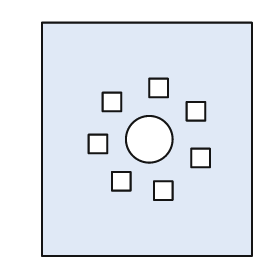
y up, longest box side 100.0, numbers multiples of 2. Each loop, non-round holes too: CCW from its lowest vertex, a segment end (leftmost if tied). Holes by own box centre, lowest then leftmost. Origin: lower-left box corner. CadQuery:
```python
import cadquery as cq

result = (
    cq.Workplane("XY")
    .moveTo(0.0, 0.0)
    .lineTo(90.0, 0.0)
    .lineTo(90.0, 100.0)
    .lineTo(0.0, 100.0)
    .close()
    .moveTo(48.0, 24.0)
    .lineTo(56.0, 24.0)
    .lineTo(56.0, 32.0)
    .lineTo(48.0, 32.0)
    .close()
    .moveTo(30.0, 28.0)
    .lineTo(38.0, 28.0)
    .lineTo(38.0, 36.0)
    .lineTo(30.0, 36.0)
    .close()
    .moveTo(64.0, 38.0)
    .lineTo(72.0, 38.0)
    .lineTo(72.0, 46.0)
    .lineTo(64.0, 46.0)
    .close()
    .moveTo(20.0, 44.0)
    .lineTo(28.0, 44.0)
    .lineTo(28.0, 52.0)
    .lineTo(20.0, 52.0)
    .close()
    .moveTo(46.0, 50.0)
    .circle(10.0)
    .moveTo(62.0, 58.0)
    .lineTo(70.0, 58.0)
    .lineTo(70.0, 66.0)
    .lineTo(62.0, 66.0)
    .close()
    .moveTo(26.0, 62.0)
    .lineTo(34.0, 62.0)
    .lineTo(34.0, 70.0)
    .lineTo(26.0, 70.0)
    .close()
    .moveTo(46.0, 68.0)
    .lineTo(54.0, 68.0)
    .lineTo(54.0, 76.0)
    .lineTo(46.0, 76.0)
    .close()
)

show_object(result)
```